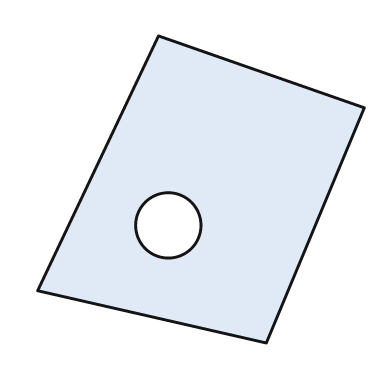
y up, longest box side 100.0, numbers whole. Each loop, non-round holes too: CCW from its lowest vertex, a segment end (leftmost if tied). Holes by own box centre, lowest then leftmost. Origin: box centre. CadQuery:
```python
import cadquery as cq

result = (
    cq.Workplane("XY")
    .moveTo(20.0, -47.0)
    .lineTo(50.0, 25.0)
    .lineTo(-13.0, 47.0)
    .lineTo(-50.0, -31.0)
    .close()
    .moveTo(-10.0, -11.0)
    .circle(10.0)
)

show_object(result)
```